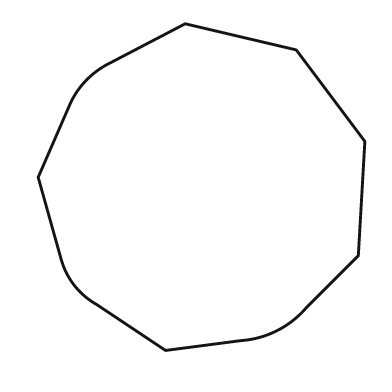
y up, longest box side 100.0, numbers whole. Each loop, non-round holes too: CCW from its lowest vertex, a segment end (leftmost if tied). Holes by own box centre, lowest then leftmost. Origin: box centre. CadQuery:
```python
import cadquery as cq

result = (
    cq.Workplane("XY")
    .moveTo(-11.0, -50.0)
    .lineTo(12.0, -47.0)
    .threePointArc((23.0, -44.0), (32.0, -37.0))
    .lineTo(48.0, -21.0)
    .lineTo(50.0, 14.0)
    .lineTo(29.0, 42.0)
    .lineTo(-5.0, 50.0)
    .lineTo(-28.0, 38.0)
    .threePointArc((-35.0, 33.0), (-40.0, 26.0))
    .lineTo(-50.0, 3.0)
    .lineTo(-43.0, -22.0)
    .threePointArc((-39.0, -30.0), (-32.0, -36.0))
    .close()
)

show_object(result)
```